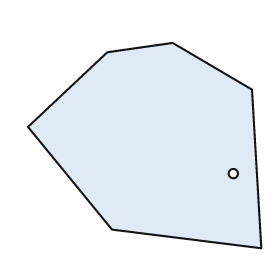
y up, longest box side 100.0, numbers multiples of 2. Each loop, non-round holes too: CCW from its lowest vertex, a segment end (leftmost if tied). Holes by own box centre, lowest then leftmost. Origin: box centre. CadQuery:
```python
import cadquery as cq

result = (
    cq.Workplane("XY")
    .moveTo(50.0, -44.0)
    .lineTo(46.0, 24.0)
    .lineTo(12.0, 44.0)
    .lineTo(-16.0, 40.0)
    .lineTo(-50.0, 8.0)
    .lineTo(-14.0, -36.0)
    .close()
    .moveTo(38.0, -12.0)
    .circle(2.0)
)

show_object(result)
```